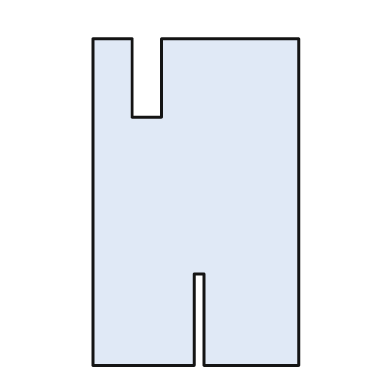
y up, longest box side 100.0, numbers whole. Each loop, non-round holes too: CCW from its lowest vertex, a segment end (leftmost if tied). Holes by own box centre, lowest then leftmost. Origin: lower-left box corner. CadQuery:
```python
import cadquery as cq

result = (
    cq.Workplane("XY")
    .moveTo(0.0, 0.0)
    .lineTo(31.0, 0.0)
    .lineTo(31.0, 28.0)
    .lineTo(34.0, 28.0)
    .lineTo(34.0, 0.0)
    .lineTo(63.0, 0.0)
    .lineTo(63.0, 100.0)
    .lineTo(21.0, 100.0)
    .lineTo(21.0, 76.0)
    .lineTo(12.0, 76.0)
    .lineTo(12.0, 100.0)
    .lineTo(0.0, 100.0)
    .close()
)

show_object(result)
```